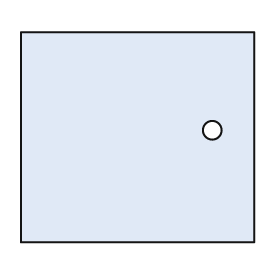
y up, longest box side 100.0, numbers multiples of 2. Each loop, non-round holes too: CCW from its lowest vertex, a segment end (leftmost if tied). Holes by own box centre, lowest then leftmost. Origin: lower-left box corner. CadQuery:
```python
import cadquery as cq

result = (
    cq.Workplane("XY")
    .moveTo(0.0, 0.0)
    .lineTo(100.0, 0.0)
    .lineTo(100.0, 90.0)
    .lineTo(0.0, 90.0)
    .close()
    .moveTo(82.0, 48.0)
    .circle(4.0)
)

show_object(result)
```